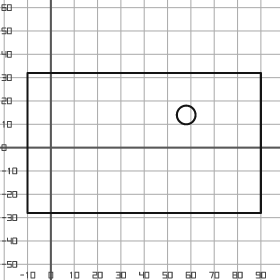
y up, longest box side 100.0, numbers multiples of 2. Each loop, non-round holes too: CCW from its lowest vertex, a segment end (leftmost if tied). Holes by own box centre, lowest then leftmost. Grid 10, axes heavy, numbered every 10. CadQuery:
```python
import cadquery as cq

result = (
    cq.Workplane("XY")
    .moveTo(-10.0, -28.0)
    .lineTo(90.0, -28.0)
    .lineTo(90.0, 32.0)
    .lineTo(-10.0, 32.0)
    .close()
    .moveTo(58.0, 14.0)
    .circle(4.0)
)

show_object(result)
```